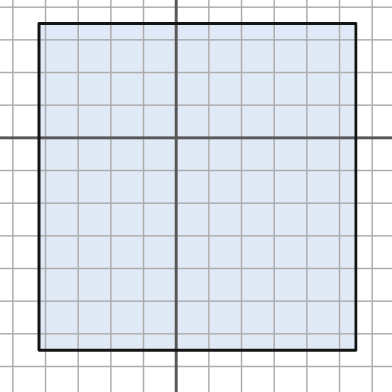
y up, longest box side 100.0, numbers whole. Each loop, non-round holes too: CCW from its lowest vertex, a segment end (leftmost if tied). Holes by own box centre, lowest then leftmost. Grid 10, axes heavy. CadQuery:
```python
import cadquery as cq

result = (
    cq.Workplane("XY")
    .moveTo(-42.0, -65.0)
    .lineTo(55.0, -65.0)
    .lineTo(55.0, 35.0)
    .lineTo(-42.0, 35.0)
    .close()
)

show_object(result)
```